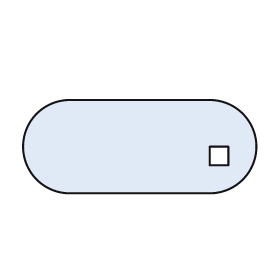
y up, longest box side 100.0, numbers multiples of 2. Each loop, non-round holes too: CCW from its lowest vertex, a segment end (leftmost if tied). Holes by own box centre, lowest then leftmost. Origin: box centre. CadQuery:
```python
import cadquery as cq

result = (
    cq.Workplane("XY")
    .moveTo(-30.0, -20.0)
    .lineTo(30.0, -20.0)
    .threePointArc((50.0, 0.0), (30.0, 20.0))
    .lineTo(-30.0, 20.0)
    .threePointArc((-50.0, 0.0), (-30.0, -20.0))
    .close()
    .moveTo(30.0, -8.0)
    .lineTo(38.0, -8.0)
    .lineTo(38.0, 0.0)
    .lineTo(30.0, 0.0)
    .close()
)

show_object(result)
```